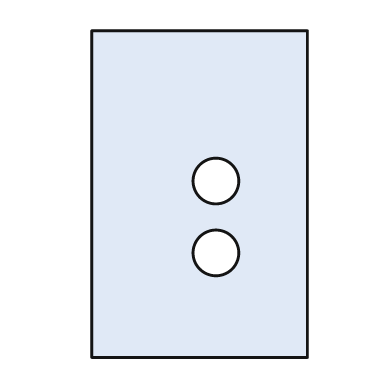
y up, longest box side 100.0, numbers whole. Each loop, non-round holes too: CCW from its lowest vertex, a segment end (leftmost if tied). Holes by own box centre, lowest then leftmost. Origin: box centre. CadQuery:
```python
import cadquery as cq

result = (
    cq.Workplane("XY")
    .moveTo(-33.0, -50.0)
    .lineTo(33.0, -50.0)
    .lineTo(33.0, 50.0)
    .lineTo(-33.0, 50.0)
    .close()
    .moveTo(5.0, -18.0)
    .circle(7.0)
    .moveTo(5.0, 4.0)
    .circle(7.0)
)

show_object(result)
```